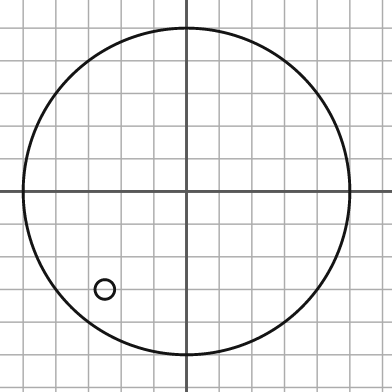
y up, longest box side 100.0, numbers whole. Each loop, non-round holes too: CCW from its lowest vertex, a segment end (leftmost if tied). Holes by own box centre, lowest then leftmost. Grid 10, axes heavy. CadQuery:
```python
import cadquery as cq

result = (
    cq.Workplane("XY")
    .moveTo(0.0, 0.0)
    .circle(50.0)
    .moveTo(-25.0, -30.0)
    .circle(3.0)
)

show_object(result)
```